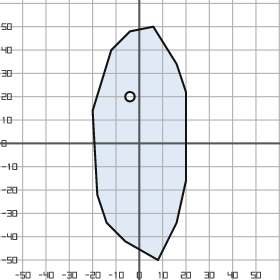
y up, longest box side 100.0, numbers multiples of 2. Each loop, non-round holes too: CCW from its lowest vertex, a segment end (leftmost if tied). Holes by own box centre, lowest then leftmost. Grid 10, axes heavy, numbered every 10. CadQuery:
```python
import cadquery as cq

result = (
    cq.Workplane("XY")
    .moveTo(8.0, -50.0)
    .lineTo(16.0, -34.0)
    .lineTo(20.0, -16.0)
    .lineTo(20.0, 22.0)
    .lineTo(16.0, 34.0)
    .lineTo(6.0, 50.0)
    .lineTo(-4.0, 48.0)
    .lineTo(-12.0, 40.0)
    .lineTo(-20.0, 14.0)
    .lineTo(-18.0, -22.0)
    .lineTo(-14.0, -34.0)
    .lineTo(-6.0, -42.0)
    .close()
    .moveTo(-4.0, 20.0)
    .circle(2.0)
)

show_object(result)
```